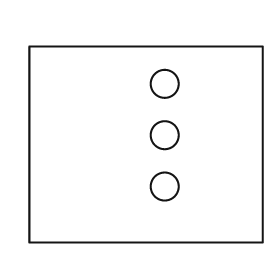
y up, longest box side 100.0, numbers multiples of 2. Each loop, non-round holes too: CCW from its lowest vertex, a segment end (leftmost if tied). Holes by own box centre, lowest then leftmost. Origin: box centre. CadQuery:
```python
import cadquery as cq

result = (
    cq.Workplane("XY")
    .moveTo(-50.0, -42.0)
    .lineTo(50.0, -42.0)
    .lineTo(50.0, 42.0)
    .lineTo(-50.0, 42.0)
    .close()
    .moveTo(8.0, -18.0)
    .circle(6.0)
    .moveTo(8.0, 4.0)
    .circle(6.0)
    .moveTo(8.0, 26.0)
    .circle(6.0)
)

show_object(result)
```